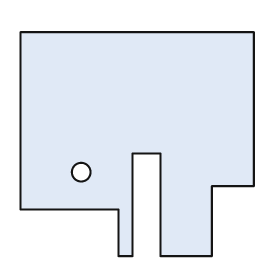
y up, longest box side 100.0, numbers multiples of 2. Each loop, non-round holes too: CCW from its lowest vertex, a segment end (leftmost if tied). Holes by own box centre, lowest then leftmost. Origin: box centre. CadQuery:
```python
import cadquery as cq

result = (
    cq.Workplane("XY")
    .moveTo(-8.0, -48.0)
    .lineTo(-2.0, -48.0)
    .lineTo(-2.0, -4.0)
    .lineTo(10.0, -4.0)
    .lineTo(10.0, -48.0)
    .lineTo(32.0, -48.0)
    .lineTo(32.0, -18.0)
    .lineTo(50.0, -18.0)
    .lineTo(50.0, 48.0)
    .lineTo(-50.0, 48.0)
    .lineTo(-50.0, -28.0)
    .lineTo(-8.0, -28.0)
    .close()
    .moveTo(-24.0, -12.0)
    .circle(4.0)
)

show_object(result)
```